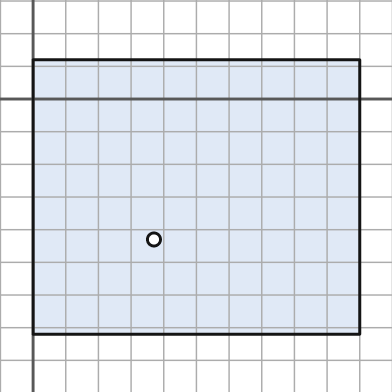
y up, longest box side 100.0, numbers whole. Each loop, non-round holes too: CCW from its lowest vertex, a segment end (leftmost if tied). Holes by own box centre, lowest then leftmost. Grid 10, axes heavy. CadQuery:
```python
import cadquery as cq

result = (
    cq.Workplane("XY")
    .moveTo(0.0, -72.0)
    .lineTo(100.0, -72.0)
    .lineTo(100.0, 12.0)
    .lineTo(0.0, 12.0)
    .close()
    .moveTo(37.0, -43.0)
    .circle(2.0)
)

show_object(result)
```